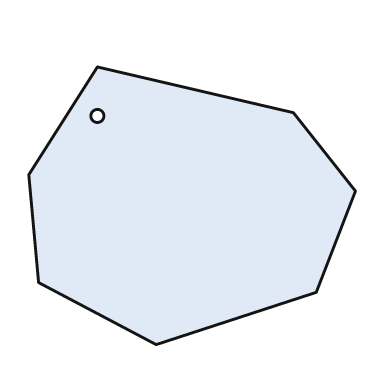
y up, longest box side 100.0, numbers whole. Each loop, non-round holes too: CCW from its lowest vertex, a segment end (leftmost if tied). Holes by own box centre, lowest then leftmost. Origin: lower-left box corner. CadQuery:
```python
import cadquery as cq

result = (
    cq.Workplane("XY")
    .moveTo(39.0, 0.0)
    .lineTo(88.0, 16.0)
    .lineTo(100.0, 47.0)
    .lineTo(81.0, 71.0)
    .lineTo(21.0, 85.0)
    .lineTo(0.0, 52.0)
    .lineTo(3.0, 19.0)
    .close()
    .moveTo(21.0, 70.0)
    .circle(2.0)
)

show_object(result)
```